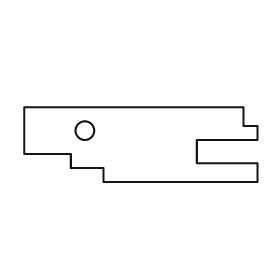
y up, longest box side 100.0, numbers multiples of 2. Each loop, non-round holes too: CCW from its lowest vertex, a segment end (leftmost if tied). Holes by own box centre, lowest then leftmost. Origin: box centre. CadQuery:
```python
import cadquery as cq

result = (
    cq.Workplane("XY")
    .moveTo(-16.0, -16.0)
    .lineTo(50.0, -16.0)
    .lineTo(50.0, -8.0)
    .lineTo(24.0, -8.0)
    .lineTo(24.0, 2.0)
    .lineTo(50.0, 2.0)
    .lineTo(50.0, 8.0)
    .lineTo(44.0, 8.0)
    .lineTo(44.0, 16.0)
    .lineTo(-50.0, 16.0)
    .lineTo(-50.0, -4.0)
    .lineTo(-30.0, -4.0)
    .lineTo(-30.0, -10.0)
    .lineTo(-16.0, -10.0)
    .close()
    .moveTo(-24.0, 6.0)
    .circle(4.0)
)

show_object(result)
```